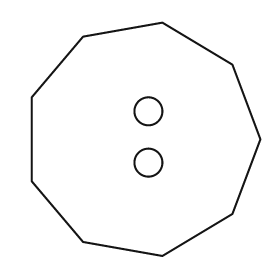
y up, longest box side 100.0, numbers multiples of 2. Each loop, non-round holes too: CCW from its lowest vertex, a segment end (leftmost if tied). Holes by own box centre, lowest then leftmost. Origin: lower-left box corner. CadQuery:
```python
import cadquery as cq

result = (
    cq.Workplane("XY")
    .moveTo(56.0, 0.0)
    .lineTo(86.0, 18.0)
    .lineTo(98.0, 50.0)
    .lineTo(86.0, 82.0)
    .lineTo(56.0, 100.0)
    .lineTo(22.0, 94.0)
    .lineTo(0.0, 68.0)
    .lineTo(0.0, 32.0)
    .lineTo(22.0, 6.0)
    .close()
    .moveTo(50.0, 40.0)
    .circle(6.0)
    .moveTo(50.0, 62.0)
    .circle(6.0)
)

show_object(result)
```